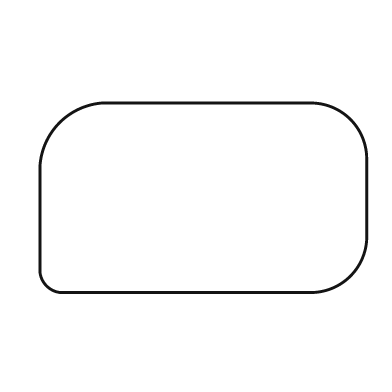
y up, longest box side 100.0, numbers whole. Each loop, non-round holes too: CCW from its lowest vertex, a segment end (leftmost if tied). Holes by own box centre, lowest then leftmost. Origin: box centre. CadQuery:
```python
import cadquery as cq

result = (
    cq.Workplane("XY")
    .moveTo(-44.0, -29.0)
    .lineTo(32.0, -29.0)
    .threePointArc((45.0, -24.0), (50.0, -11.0))
    .lineTo(50.0, 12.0)
    .threePointArc((45.0, 24.0), (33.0, 29.0))
    .lineTo(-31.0, 29.0)
    .threePointArc((-44.0, 23.0), (-50.0, 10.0))
    .lineTo(-50.0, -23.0)
    .threePointArc((-48.0, -27.0), (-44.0, -29.0))
    .close()
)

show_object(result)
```